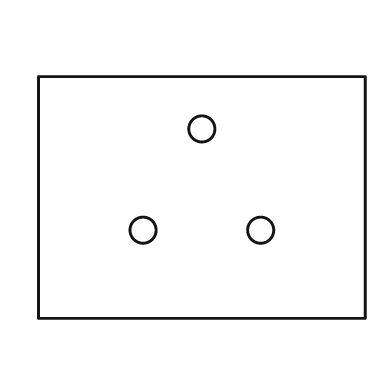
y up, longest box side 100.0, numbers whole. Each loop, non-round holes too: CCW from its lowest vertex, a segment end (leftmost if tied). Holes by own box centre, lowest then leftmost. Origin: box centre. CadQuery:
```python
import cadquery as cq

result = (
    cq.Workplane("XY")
    .moveTo(-50.0, -37.0)
    .lineTo(50.0, -37.0)
    .lineTo(50.0, 37.0)
    .lineTo(-50.0, 37.0)
    .close()
    .moveTo(-18.0, -10.0)
    .circle(4.0)
    .moveTo(18.0, -10.0)
    .circle(4.0)
    .moveTo(0.0, 21.0)
    .circle(4.0)
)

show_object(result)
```